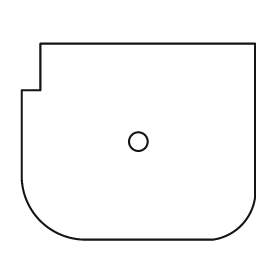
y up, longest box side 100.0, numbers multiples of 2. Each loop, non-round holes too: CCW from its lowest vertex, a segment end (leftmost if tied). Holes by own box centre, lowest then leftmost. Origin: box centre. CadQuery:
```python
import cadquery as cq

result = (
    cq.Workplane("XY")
    .moveTo(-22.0, -42.0)
    .lineTo(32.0, -42.0)
    .threePointArc((44.0, -36.0), (50.0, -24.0))
    .lineTo(50.0, 42.0)
    .lineTo(-42.0, 42.0)
    .lineTo(-42.0, 22.0)
    .lineTo(-50.0, 22.0)
    .lineTo(-50.0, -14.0)
    .threePointArc((-42.0, -34.0), (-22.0, -42.0))
    .close()
    .moveTo(0.0, 0.0)
    .circle(4.0)
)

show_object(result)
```